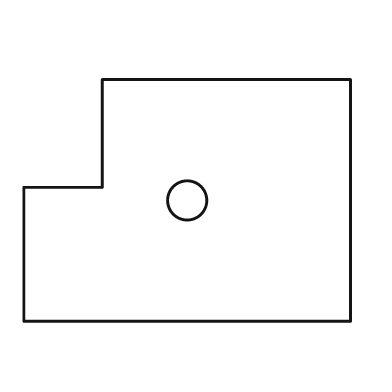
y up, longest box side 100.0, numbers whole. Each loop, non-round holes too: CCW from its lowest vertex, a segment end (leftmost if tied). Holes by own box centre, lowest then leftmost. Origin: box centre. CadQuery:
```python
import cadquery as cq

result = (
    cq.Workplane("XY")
    .moveTo(-50.0, -37.0)
    .lineTo(50.0, -37.0)
    .lineTo(50.0, 37.0)
    .lineTo(-26.0, 37.0)
    .lineTo(-26.0, 4.0)
    .lineTo(-50.0, 4.0)
    .close()
    .moveTo(0.0, 0.0)
    .circle(6.0)
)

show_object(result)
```